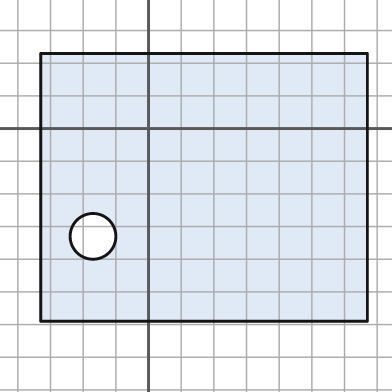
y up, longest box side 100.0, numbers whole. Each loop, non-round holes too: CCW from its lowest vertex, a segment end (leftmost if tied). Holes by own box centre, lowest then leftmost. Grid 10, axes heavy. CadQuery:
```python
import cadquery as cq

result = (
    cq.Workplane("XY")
    .moveTo(-33.0, -59.0)
    .lineTo(67.0, -59.0)
    .lineTo(67.0, 23.0)
    .lineTo(-33.0, 23.0)
    .close()
    .moveTo(-17.0, -33.0)
    .circle(7.0)
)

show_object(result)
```